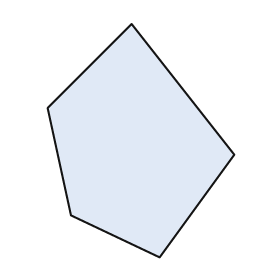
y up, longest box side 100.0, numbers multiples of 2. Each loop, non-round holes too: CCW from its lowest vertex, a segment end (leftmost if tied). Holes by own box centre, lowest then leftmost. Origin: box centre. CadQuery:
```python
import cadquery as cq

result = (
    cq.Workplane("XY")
    .moveTo(8.0, -50.0)
    .lineTo(40.0, -6.0)
    .lineTo(-4.0, 50.0)
    .lineTo(-40.0, 14.0)
    .lineTo(-30.0, -32.0)
    .close()
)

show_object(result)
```